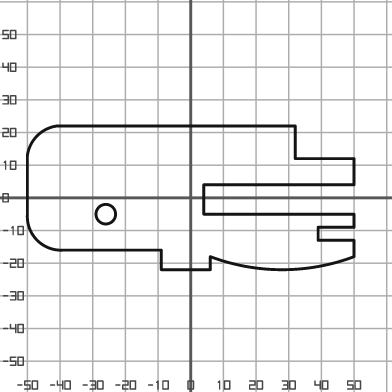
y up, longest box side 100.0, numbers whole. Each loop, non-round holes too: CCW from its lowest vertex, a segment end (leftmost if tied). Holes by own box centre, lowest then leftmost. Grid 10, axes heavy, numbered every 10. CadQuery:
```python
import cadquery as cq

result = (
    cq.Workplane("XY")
    .moveTo(-9.0, -22.0)
    .lineTo(6.0, -22.0)
    .lineTo(6.0, -18.0)
    .threePointArc((28.0, -22.0), (50.0, -18.0))
    .lineTo(50.0, -13.0)
    .lineTo(39.0, -13.0)
    .lineTo(39.0, -9.0)
    .lineTo(50.0, -9.0)
    .lineTo(50.0, -5.0)
    .lineTo(4.0, -5.0)
    .lineTo(4.0, 4.0)
    .lineTo(50.0, 4.0)
    .lineTo(50.0, 12.0)
    .lineTo(32.0, 12.0)
    .lineTo(32.0, 22.0)
    .lineTo(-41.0, 22.0)
    .threePointArc((-47.0, 19.0), (-50.0, 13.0))
    .lineTo(-50.0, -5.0)
    .threePointArc((-47.0, -13.0), (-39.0, -16.0))
    .lineTo(-9.0, -16.0)
    .close()
    .moveTo(-26.0, -5.0)
    .circle(3.0)
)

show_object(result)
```